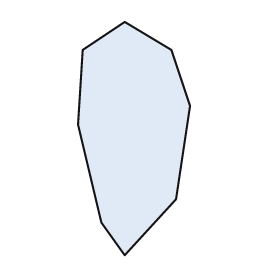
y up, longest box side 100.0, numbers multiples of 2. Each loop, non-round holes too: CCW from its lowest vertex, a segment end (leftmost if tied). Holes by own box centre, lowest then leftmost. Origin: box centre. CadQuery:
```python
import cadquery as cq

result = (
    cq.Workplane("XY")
    .moveTo(-4.0, -50.0)
    .lineTo(18.0, -26.0)
    .lineTo(24.0, 14.0)
    .lineTo(16.0, 38.0)
    .lineTo(-4.0, 50.0)
    .lineTo(-22.0, 38.0)
    .lineTo(-24.0, 6.0)
    .lineTo(-14.0, -36.0)
    .close()
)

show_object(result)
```